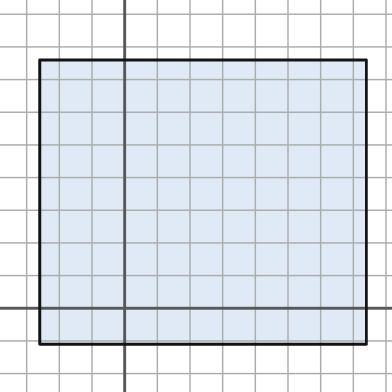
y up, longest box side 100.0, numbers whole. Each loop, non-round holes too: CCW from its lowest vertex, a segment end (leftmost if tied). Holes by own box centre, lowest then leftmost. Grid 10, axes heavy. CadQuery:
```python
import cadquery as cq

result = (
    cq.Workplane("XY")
    .moveTo(-26.0, -11.0)
    .lineTo(74.0, -11.0)
    .lineTo(74.0, 76.0)
    .lineTo(-26.0, 76.0)
    .close()
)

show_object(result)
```